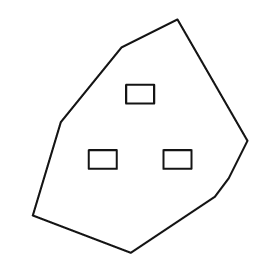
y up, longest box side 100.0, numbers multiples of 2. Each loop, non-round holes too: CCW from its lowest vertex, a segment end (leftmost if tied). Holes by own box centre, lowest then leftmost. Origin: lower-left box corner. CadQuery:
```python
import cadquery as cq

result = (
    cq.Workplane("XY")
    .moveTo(42.0, 0.0)
    .lineTo(78.0, 24.0)
    .lineTo(84.0, 32.0)
    .lineTo(92.0, 48.0)
    .lineTo(62.0, 100.0)
    .lineTo(38.0, 88.0)
    .lineTo(12.0, 56.0)
    .lineTo(0.0, 16.0)
    .close()
    .moveTo(24.0, 36.0)
    .lineTo(36.0, 36.0)
    .lineTo(36.0, 44.0)
    .lineTo(24.0, 44.0)
    .close()
    .moveTo(56.0, 36.0)
    .lineTo(68.0, 36.0)
    .lineTo(68.0, 44.0)
    .lineTo(56.0, 44.0)
    .close()
    .moveTo(40.0, 64.0)
    .lineTo(52.0, 64.0)
    .lineTo(52.0, 72.0)
    .lineTo(40.0, 72.0)
    .close()
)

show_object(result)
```